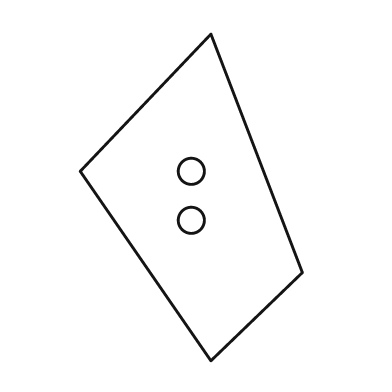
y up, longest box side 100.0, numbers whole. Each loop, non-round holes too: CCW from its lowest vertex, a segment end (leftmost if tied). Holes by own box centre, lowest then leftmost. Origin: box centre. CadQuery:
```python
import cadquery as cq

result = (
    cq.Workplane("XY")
    .moveTo(6.0, -50.0)
    .lineTo(34.0, -23.0)
    .lineTo(6.0, 50.0)
    .lineTo(-34.0, 8.0)
    .close()
    .moveTo(0.0, -7.0)
    .circle(4.0)
    .moveTo(0.0, 8.0)
    .circle(4.0)
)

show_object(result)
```